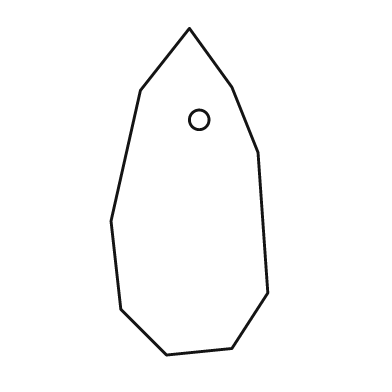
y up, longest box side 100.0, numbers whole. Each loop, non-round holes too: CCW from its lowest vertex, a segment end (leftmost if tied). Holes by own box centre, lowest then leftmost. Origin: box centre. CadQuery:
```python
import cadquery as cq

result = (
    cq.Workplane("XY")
    .moveTo(-7.0, -50.0)
    .lineTo(13.0, -48.0)
    .lineTo(24.0, -31.0)
    .lineTo(21.0, 12.0)
    .lineTo(13.0, 32.0)
    .lineTo(0.0, 50.0)
    .lineTo(-15.0, 31.0)
    .lineTo(-24.0, -9.0)
    .lineTo(-21.0, -36.0)
    .close()
    .moveTo(3.0, 22.0)
    .circle(3.0)
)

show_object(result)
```